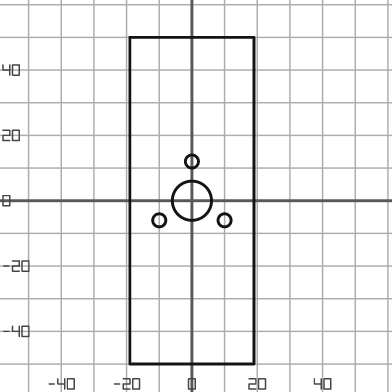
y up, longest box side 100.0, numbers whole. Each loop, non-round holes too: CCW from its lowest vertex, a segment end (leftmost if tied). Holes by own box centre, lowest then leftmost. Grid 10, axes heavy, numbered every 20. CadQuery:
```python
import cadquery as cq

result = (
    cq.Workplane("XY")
    .moveTo(-19.0, -50.0)
    .lineTo(19.0, -50.0)
    .lineTo(19.0, 50.0)
    .lineTo(-19.0, 50.0)
    .close()
    .moveTo(-10.0, -6.0)
    .circle(2.0)
    .moveTo(10.0, -6.0)
    .circle(2.0)
    .moveTo(0.0, 0.0)
    .circle(6.0)
    .moveTo(0.0, 12.0)
    .circle(2.0)
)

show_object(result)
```